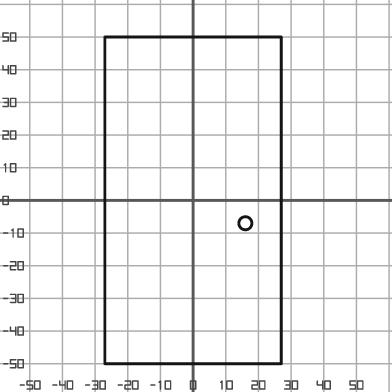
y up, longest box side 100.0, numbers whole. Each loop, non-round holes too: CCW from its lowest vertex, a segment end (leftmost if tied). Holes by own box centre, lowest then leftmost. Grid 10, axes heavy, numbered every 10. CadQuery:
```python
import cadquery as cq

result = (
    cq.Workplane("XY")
    .moveTo(-27.0, -50.0)
    .lineTo(27.0, -50.0)
    .lineTo(27.0, 50.0)
    .lineTo(-27.0, 50.0)
    .close()
    .moveTo(16.0, -7.0)
    .circle(2.0)
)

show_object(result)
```